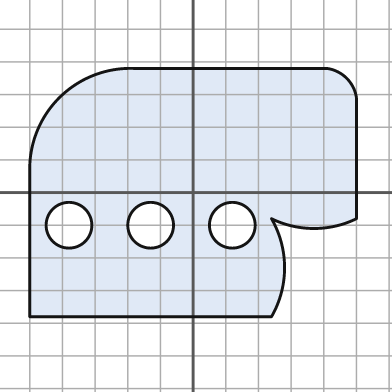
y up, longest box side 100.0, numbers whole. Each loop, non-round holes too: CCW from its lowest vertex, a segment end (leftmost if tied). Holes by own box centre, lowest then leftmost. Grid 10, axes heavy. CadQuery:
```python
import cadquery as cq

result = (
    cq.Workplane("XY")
    .moveTo(-50.0, -38.0)
    .lineTo(24.0, -38.0)
    .threePointArc((28.0, -23.0), (24.0, -8.0))
    .threePointArc((37.0, -11.0), (50.0, -8.0))
    .lineTo(50.0, 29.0)
    .threePointArc((47.0, 35.0), (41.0, 38.0))
    .lineTo(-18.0, 38.0)
    .threePointArc((-41.0, 29.0), (-50.0, 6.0))
    .close()
    .moveTo(-38.0, -10.0)
    .circle(7.0)
    .moveTo(-13.0, -10.0)
    .circle(7.0)
    .moveTo(12.0, -10.0)
    .circle(7.0)
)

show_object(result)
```